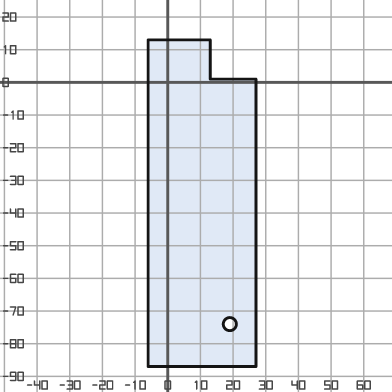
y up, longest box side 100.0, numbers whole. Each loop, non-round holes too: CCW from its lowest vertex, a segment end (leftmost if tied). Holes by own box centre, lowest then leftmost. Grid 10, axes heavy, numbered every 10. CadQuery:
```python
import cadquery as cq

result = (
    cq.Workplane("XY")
    .moveTo(-6.0, -87.0)
    .lineTo(27.0, -87.0)
    .lineTo(27.0, 1.0)
    .lineTo(13.0, 1.0)
    .lineTo(13.0, 13.0)
    .lineTo(-6.0, 13.0)
    .close()
    .moveTo(19.0, -74.0)
    .circle(2.0)
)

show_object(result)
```